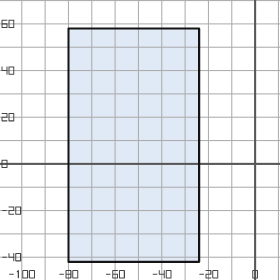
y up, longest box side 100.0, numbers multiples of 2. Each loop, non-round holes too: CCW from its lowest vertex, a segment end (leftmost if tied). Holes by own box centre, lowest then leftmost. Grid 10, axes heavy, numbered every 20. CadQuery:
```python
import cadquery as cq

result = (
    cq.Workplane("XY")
    .moveTo(-80.0, -42.0)
    .lineTo(-24.0, -42.0)
    .lineTo(-24.0, 58.0)
    .lineTo(-80.0, 58.0)
    .close()
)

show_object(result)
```